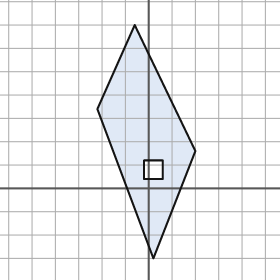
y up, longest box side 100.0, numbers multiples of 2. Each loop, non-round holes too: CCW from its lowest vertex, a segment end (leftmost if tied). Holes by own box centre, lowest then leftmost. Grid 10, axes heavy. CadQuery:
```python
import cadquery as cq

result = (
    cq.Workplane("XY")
    .moveTo(2.0, -30.0)
    .lineTo(20.0, 16.0)
    .lineTo(-6.0, 70.0)
    .lineTo(-22.0, 34.0)
    .close()
    .moveTo(-2.0, 4.0)
    .lineTo(6.0, 4.0)
    .lineTo(6.0, 12.0)
    .lineTo(-2.0, 12.0)
    .close()
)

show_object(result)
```